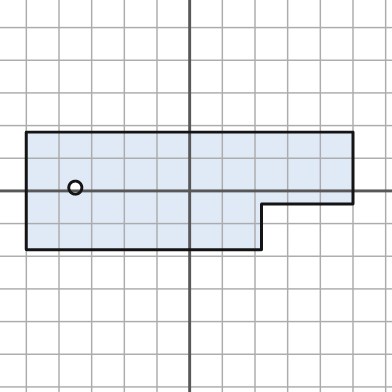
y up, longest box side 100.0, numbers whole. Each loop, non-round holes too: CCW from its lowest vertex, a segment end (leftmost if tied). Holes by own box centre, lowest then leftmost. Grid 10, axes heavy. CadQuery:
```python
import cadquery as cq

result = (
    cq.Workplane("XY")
    .moveTo(-50.0, -18.0)
    .lineTo(22.0, -18.0)
    .lineTo(22.0, -4.0)
    .lineTo(50.0, -4.0)
    .lineTo(50.0, 18.0)
    .lineTo(-50.0, 18.0)
    .close()
    .moveTo(-35.0, 1.0)
    .circle(2.0)
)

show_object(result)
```